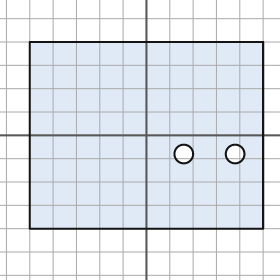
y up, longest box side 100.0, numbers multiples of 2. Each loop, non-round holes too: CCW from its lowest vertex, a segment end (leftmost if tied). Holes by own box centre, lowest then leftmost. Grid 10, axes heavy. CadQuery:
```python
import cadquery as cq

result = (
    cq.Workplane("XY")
    .moveTo(-50.0, -40.0)
    .lineTo(50.0, -40.0)
    .lineTo(50.0, 40.0)
    .lineTo(-50.0, 40.0)
    .close()
    .moveTo(16.0, -8.0)
    .circle(4.0)
    .moveTo(38.0, -8.0)
    .circle(4.0)
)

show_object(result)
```